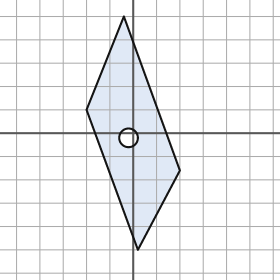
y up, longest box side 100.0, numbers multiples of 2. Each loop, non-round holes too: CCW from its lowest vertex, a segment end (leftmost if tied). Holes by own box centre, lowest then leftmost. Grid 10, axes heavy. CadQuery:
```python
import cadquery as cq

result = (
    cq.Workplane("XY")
    .moveTo(2.0, -50.0)
    .lineTo(20.0, -16.0)
    .lineTo(-4.0, 50.0)
    .lineTo(-20.0, 10.0)
    .close()
    .moveTo(-2.0, -2.0)
    .circle(4.0)
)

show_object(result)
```